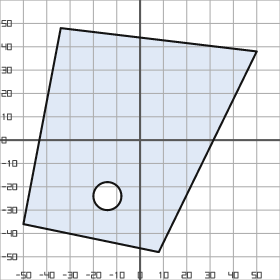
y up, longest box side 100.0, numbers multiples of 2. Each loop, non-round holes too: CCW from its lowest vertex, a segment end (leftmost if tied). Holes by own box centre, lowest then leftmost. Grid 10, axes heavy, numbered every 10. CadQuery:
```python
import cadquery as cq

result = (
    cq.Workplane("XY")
    .moveTo(8.0, -48.0)
    .lineTo(50.0, 38.0)
    .lineTo(-34.0, 48.0)
    .lineTo(-50.0, -36.0)
    .close()
    .moveTo(-14.0, -24.0)
    .circle(6.0)
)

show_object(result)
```